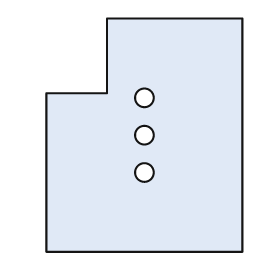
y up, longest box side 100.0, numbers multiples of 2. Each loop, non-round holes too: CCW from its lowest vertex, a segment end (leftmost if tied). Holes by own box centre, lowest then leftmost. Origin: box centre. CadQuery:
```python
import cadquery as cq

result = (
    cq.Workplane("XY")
    .moveTo(-42.0, -50.0)
    .lineTo(42.0, -50.0)
    .lineTo(42.0, 50.0)
    .lineTo(-16.0, 50.0)
    .lineTo(-16.0, 18.0)
    .lineTo(-42.0, 18.0)
    .close()
    .moveTo(0.0, -16.0)
    .circle(4.0)
    .moveTo(0.0, 0.0)
    .circle(4.0)
    .moveTo(0.0, 16.0)
    .circle(4.0)
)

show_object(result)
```